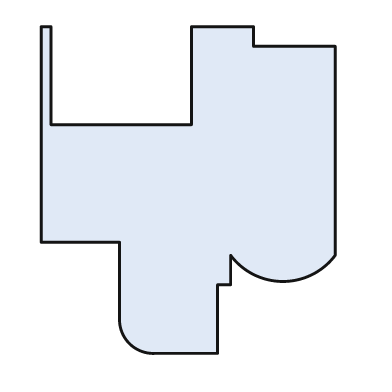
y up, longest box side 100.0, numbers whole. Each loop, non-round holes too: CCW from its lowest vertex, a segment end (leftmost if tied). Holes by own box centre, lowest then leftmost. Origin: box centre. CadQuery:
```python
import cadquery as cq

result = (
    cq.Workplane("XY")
    .moveTo(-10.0, -50.0)
    .lineTo(9.0, -50.0)
    .lineTo(9.0, -29.0)
    .lineTo(13.0, -29.0)
    .lineTo(13.0, -20.0)
    .threePointArc((29.0, -28.0), (45.0, -20.0))
    .lineTo(45.0, 44.0)
    .lineTo(20.0, 44.0)
    .lineTo(20.0, 50.0)
    .lineTo(1.0, 50.0)
    .lineTo(1.0, 20.0)
    .lineTo(-42.0, 20.0)
    .lineTo(-42.0, 50.0)
    .lineTo(-45.0, 50.0)
    .lineTo(-45.0, -16.0)
    .lineTo(-21.0, -16.0)
    .lineTo(-21.0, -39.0)
    .threePointArc((-18.0, -47.0), (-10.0, -50.0))
    .close()
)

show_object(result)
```